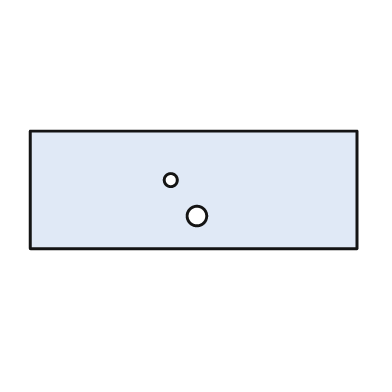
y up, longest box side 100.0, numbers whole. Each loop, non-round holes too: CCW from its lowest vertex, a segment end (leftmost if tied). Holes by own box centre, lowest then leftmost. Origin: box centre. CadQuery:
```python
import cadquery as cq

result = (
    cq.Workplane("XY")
    .moveTo(-50.0, -18.0)
    .lineTo(50.0, -18.0)
    .lineTo(50.0, 18.0)
    .lineTo(-50.0, 18.0)
    .close()
    .moveTo(1.0, -8.0)
    .circle(3.0)
    .moveTo(-7.0, 3.0)
    .circle(2.0)
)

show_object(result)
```